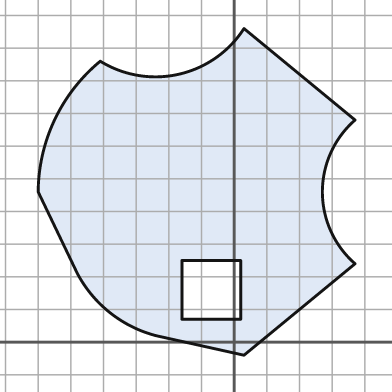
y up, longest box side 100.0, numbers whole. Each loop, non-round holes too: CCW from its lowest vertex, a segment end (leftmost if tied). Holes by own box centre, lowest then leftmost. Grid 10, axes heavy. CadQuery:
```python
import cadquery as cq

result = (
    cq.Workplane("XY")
    .moveTo(3.0, -4.0)
    .lineTo(37.0, 24.0)
    .threePointArc((27.0, 46.0), (37.0, 68.0))
    .lineTo(3.0, 96.0)
    .threePointArc((-17.0, 82.0), (-41.0, 86.0))
    .threePointArc((-55.0, 68.0), (-60.0, 46.0))
    .lineTo(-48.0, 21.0)
    .threePointArc((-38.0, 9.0), (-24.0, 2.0))
    .close()
    .moveTo(-16.0, 7.0)
    .lineTo(2.0, 7.0)
    .lineTo(2.0, 25.0)
    .lineTo(-16.0, 25.0)
    .close()
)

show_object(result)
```